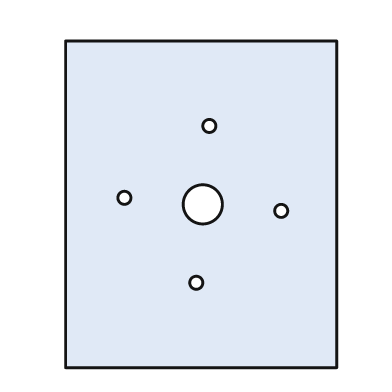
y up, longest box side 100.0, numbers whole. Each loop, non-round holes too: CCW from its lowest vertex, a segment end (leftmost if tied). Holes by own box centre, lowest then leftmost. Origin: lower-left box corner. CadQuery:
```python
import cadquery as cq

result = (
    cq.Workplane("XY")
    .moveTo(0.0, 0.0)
    .lineTo(83.0, 0.0)
    .lineTo(83.0, 100.0)
    .lineTo(0.0, 100.0)
    .close()
    .moveTo(40.0, 26.0)
    .circle(2.0)
    .moveTo(66.0, 48.0)
    .circle(2.0)
    .moveTo(42.0, 50.0)
    .circle(6.0)
    .moveTo(18.0, 52.0)
    .circle(2.0)
    .moveTo(44.0, 74.0)
    .circle(2.0)
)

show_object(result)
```